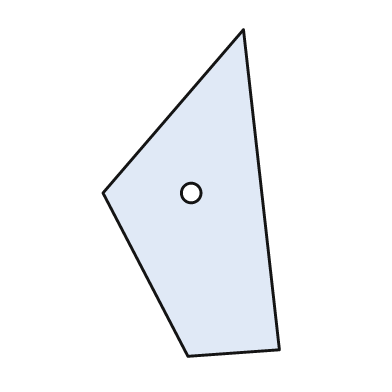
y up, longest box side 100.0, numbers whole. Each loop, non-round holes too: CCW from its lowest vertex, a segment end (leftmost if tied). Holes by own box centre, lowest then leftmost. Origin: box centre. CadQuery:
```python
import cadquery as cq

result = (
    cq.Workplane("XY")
    .moveTo(-1.0, -50.0)
    .lineTo(27.0, -48.0)
    .lineTo(16.0, 50.0)
    .lineTo(-27.0, 0.0)
    .close()
    .moveTo(0.0, 0.0)
    .circle(3.0)
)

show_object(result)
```